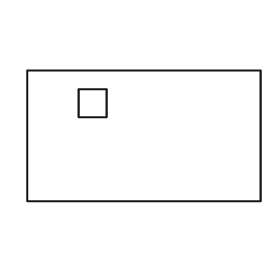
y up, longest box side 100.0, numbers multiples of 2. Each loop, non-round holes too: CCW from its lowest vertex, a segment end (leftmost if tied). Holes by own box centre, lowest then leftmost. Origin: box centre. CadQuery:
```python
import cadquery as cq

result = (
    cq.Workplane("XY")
    .moveTo(-50.0, -28.0)
    .lineTo(50.0, -28.0)
    .lineTo(50.0, 28.0)
    .lineTo(-50.0, 28.0)
    .close()
    .moveTo(-28.0, 8.0)
    .lineTo(-16.0, 8.0)
    .lineTo(-16.0, 20.0)
    .lineTo(-28.0, 20.0)
    .close()
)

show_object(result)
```